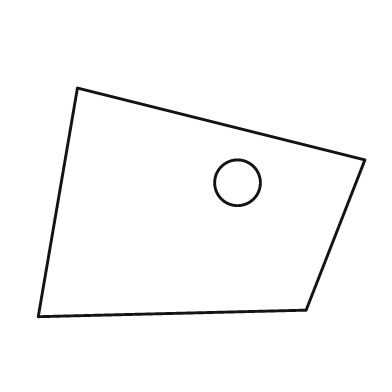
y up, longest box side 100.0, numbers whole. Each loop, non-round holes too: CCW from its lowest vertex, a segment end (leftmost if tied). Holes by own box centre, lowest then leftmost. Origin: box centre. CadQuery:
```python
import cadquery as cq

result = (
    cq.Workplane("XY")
    .moveTo(-50.0, -35.0)
    .lineTo(32.0, -33.0)
    .lineTo(50.0, 13.0)
    .lineTo(-38.0, 35.0)
    .close()
    .moveTo(11.0, 6.0)
    .circle(7.0)
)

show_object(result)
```